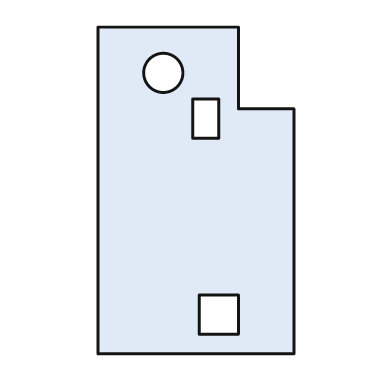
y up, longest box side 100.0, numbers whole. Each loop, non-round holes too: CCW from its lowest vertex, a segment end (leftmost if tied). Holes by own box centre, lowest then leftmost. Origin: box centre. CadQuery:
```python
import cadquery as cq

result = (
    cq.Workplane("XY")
    .moveTo(-30.0, -50.0)
    .lineTo(30.0, -50.0)
    .lineTo(30.0, 25.0)
    .lineTo(13.0, 25.0)
    .lineTo(13.0, 50.0)
    .lineTo(-30.0, 50.0)
    .close()
    .moveTo(1.0, -44.0)
    .lineTo(13.0, -44.0)
    .lineTo(13.0, -32.0)
    .lineTo(1.0, -32.0)
    .close()
    .moveTo(-1.0, 16.0)
    .lineTo(7.0, 16.0)
    .lineTo(7.0, 28.0)
    .lineTo(-1.0, 28.0)
    .close()
    .moveTo(-10.0, 36.0)
    .circle(6.0)
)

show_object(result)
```